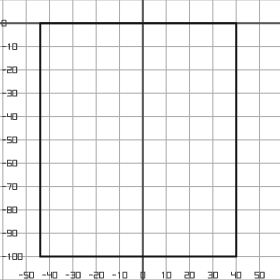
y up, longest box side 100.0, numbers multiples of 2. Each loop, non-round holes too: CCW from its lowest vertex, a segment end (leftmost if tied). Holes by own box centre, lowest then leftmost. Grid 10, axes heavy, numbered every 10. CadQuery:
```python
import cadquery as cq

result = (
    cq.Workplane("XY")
    .moveTo(-44.0, -100.0)
    .lineTo(40.0, -100.0)
    .lineTo(40.0, 0.0)
    .lineTo(-44.0, 0.0)
    .close()
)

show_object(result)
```